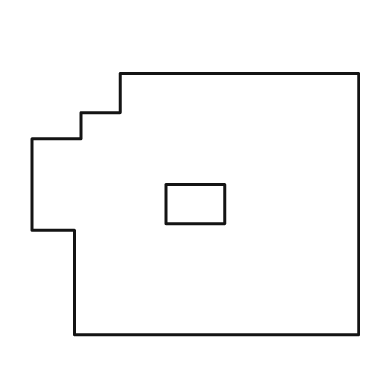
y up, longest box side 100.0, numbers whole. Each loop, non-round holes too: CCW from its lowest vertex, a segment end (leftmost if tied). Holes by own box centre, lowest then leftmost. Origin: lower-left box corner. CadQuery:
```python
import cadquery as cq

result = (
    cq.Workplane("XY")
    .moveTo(13.0, 0.0)
    .lineTo(100.0, 0.0)
    .lineTo(100.0, 80.0)
    .lineTo(27.0, 80.0)
    .lineTo(27.0, 68.0)
    .lineTo(15.0, 68.0)
    .lineTo(15.0, 60.0)
    .lineTo(0.0, 60.0)
    .lineTo(0.0, 32.0)
    .lineTo(13.0, 32.0)
    .close()
    .moveTo(41.0, 34.0)
    .lineTo(59.0, 34.0)
    .lineTo(59.0, 46.0)
    .lineTo(41.0, 46.0)
    .close()
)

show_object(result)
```